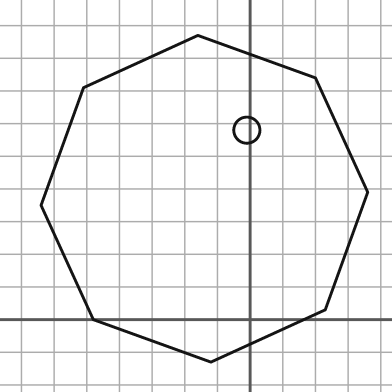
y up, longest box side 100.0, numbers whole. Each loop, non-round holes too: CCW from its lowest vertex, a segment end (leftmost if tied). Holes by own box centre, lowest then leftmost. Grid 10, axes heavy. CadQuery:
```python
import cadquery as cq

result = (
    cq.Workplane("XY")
    .moveTo(-12.0, -13.0)
    .lineTo(23.0, 3.0)
    .lineTo(36.0, 39.0)
    .lineTo(20.0, 74.0)
    .lineTo(-16.0, 87.0)
    .lineTo(-51.0, 71.0)
    .lineTo(-64.0, 35.0)
    .lineTo(-48.0, 0.0)
    .close()
    .moveTo(-1.0, 58.0)
    .circle(4.0)
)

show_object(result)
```